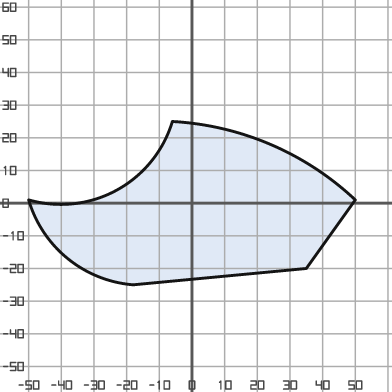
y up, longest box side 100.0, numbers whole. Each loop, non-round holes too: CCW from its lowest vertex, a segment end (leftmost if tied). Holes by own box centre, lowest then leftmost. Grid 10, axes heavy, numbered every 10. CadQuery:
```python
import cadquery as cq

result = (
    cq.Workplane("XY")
    .moveTo(-18.0, -25.0)
    .lineTo(35.0, -20.0)
    .lineTo(50.0, 1.0)
    .threePointArc((24.0, 18.0), (-6.0, 25.0))
    .threePointArc((-23.0, 4.0), (-50.0, 1.0))
    .threePointArc((-38.0, -17.0), (-18.0, -25.0))
    .close()
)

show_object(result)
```